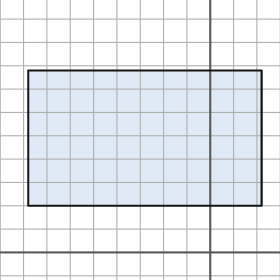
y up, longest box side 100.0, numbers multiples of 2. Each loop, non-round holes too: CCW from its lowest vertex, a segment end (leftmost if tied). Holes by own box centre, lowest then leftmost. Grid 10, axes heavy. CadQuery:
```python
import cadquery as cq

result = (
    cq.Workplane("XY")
    .moveTo(-78.0, 20.0)
    .lineTo(22.0, 20.0)
    .lineTo(22.0, 78.0)
    .lineTo(-78.0, 78.0)
    .close()
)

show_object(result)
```